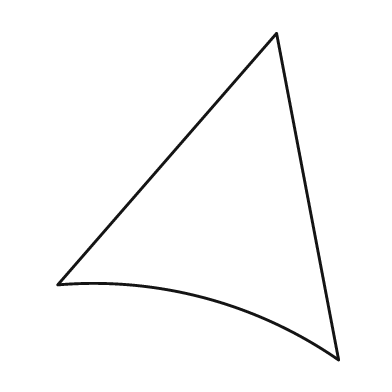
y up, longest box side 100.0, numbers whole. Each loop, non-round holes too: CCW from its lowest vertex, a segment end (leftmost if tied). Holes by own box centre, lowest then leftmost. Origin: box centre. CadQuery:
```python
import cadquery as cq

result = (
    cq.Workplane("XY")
    .moveTo(43.0, -50.0)
    .lineTo(24.0, 50.0)
    .lineTo(-43.0, -27.0)
    .threePointArc((2.0, -31.0), (43.0, -50.0))
    .close()
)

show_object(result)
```